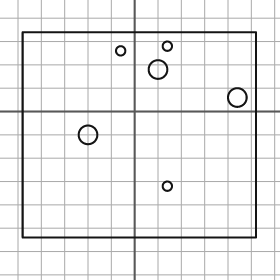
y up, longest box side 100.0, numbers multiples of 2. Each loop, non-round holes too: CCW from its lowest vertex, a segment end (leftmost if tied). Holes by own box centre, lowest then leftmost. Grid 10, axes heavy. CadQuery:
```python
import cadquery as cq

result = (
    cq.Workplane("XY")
    .moveTo(-48.0, -54.0)
    .lineTo(52.0, -54.0)
    .lineTo(52.0, 34.0)
    .lineTo(-48.0, 34.0)
    .close()
    .moveTo(14.0, -32.0)
    .circle(2.0)
    .moveTo(-20.0, -10.0)
    .circle(4.0)
    .moveTo(44.0, 6.0)
    .circle(4.0)
    .moveTo(10.0, 18.0)
    .circle(4.0)
    .moveTo(-6.0, 26.0)
    .circle(2.0)
    .moveTo(14.0, 28.0)
    .circle(2.0)
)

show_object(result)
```